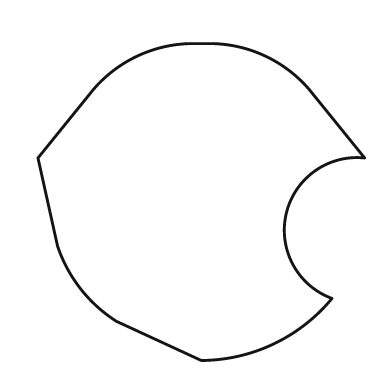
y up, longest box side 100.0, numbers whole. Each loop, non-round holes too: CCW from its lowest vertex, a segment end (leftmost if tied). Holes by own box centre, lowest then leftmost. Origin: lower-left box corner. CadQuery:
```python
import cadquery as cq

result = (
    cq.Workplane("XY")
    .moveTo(50.0, 0.0)
    .threePointArc((72.0, 5.0), (90.0, 19.0))
    .threePointArc((76.0, 45.0), (100.0, 62.0))
    .lineTo(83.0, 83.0)
    .threePointArc((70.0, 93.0), (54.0, 97.0))
    .lineTo(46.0, 97.0)
    .threePointArc((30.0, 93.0), (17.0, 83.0))
    .lineTo(0.0, 62.0)
    .lineTo(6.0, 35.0)
    .threePointArc((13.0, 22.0), (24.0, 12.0))
    .close()
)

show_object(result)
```